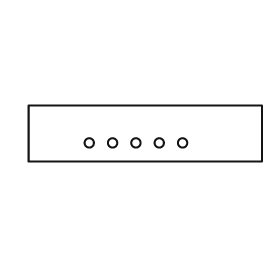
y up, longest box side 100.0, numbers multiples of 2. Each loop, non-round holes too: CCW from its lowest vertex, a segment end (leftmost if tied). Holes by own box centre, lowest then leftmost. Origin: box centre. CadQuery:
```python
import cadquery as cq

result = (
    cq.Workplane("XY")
    .moveTo(-50.0, -12.0)
    .lineTo(50.0, -12.0)
    .lineTo(50.0, 12.0)
    .lineTo(-50.0, 12.0)
    .close()
    .moveTo(-24.0, -4.0)
    .circle(2.0)
    .moveTo(-14.0, -4.0)
    .circle(2.0)
    .moveTo(-4.0, -4.0)
    .circle(2.0)
    .moveTo(6.0, -4.0)
    .circle(2.0)
    .moveTo(16.0, -4.0)
    .circle(2.0)
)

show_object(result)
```